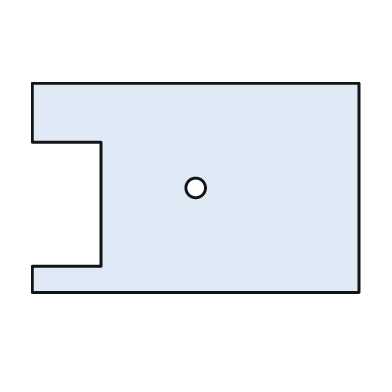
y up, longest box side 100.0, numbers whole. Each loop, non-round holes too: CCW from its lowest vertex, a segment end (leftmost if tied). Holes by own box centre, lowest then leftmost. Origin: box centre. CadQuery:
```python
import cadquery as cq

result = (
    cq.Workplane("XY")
    .moveTo(-50.0, -32.0)
    .lineTo(50.0, -32.0)
    .lineTo(50.0, 32.0)
    .lineTo(-50.0, 32.0)
    .lineTo(-50.0, 14.0)
    .lineTo(-29.0, 14.0)
    .lineTo(-29.0, -24.0)
    .lineTo(-50.0, -24.0)
    .close()
    .moveTo(0.0, 0.0)
    .circle(3.0)
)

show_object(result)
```